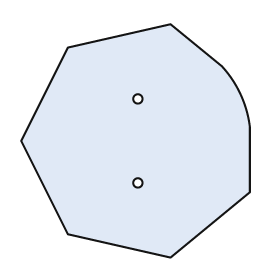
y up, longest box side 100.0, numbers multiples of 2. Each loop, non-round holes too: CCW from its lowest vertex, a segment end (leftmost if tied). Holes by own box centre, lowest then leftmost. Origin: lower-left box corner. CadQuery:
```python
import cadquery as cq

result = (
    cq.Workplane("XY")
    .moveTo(64.0, 0.0)
    .lineTo(98.0, 28.0)
    .lineTo(98.0, 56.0)
    .threePointArc((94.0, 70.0), (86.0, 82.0))
    .lineTo(64.0, 100.0)
    .lineTo(20.0, 90.0)
    .lineTo(0.0, 50.0)
    .lineTo(20.0, 10.0)
    .close()
    .moveTo(50.0, 32.0)
    .circle(2.0)
    .moveTo(50.0, 68.0)
    .circle(2.0)
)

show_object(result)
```